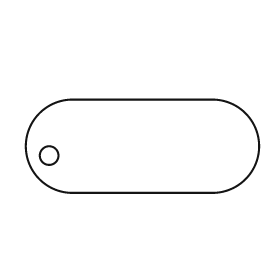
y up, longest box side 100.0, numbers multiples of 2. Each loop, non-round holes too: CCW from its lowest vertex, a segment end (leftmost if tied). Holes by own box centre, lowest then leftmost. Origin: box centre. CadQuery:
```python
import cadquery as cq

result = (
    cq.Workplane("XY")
    .moveTo(-30.0, -20.0)
    .lineTo(30.0, -20.0)
    .threePointArc((50.0, 0.0), (30.0, 20.0))
    .lineTo(-30.0, 20.0)
    .threePointArc((-50.0, 0.0), (-30.0, -20.0))
    .close()
    .moveTo(-40.0, -4.0)
    .circle(4.0)
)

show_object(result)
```